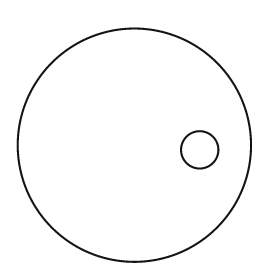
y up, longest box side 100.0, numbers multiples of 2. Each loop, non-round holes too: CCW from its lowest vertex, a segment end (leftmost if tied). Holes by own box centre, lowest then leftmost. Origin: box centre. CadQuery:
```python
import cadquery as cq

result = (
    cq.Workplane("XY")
    .moveTo(0.0, 0.0)
    .circle(50.0)
    .moveTo(28.0, -2.0)
    .circle(8.0)
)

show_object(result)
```